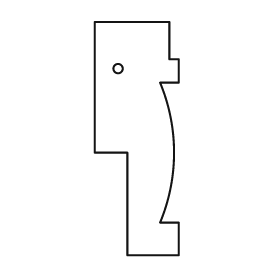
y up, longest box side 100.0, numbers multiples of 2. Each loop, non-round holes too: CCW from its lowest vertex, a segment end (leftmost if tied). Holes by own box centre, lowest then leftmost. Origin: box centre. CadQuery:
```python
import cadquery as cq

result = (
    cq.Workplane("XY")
    .moveTo(-4.0, -50.0)
    .lineTo(18.0, -50.0)
    .lineTo(18.0, -36.0)
    .lineTo(10.0, -36.0)
    .threePointArc((16.0, -6.0), (10.0, 24.0))
    .lineTo(18.0, 24.0)
    .lineTo(18.0, 34.0)
    .lineTo(14.0, 34.0)
    .lineTo(14.0, 50.0)
    .lineTo(-18.0, 50.0)
    .lineTo(-18.0, -6.0)
    .lineTo(-4.0, -6.0)
    .close()
    .moveTo(-8.0, 30.0)
    .circle(2.0)
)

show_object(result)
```